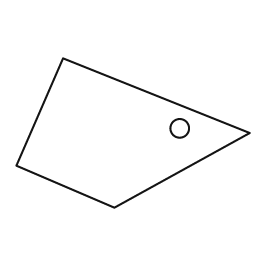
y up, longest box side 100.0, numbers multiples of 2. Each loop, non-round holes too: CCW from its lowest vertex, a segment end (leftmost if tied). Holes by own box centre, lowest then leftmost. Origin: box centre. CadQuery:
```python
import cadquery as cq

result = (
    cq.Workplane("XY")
    .moveTo(-8.0, -32.0)
    .lineTo(50.0, 0.0)
    .lineTo(-30.0, 32.0)
    .lineTo(-50.0, -14.0)
    .close()
    .moveTo(20.0, 2.0)
    .circle(4.0)
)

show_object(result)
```